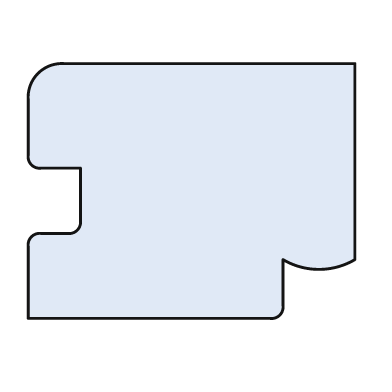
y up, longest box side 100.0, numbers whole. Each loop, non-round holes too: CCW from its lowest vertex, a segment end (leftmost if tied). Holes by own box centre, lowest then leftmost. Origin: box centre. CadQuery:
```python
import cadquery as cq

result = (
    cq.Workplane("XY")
    .moveTo(-50.0, -39.0)
    .lineTo(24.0, -39.0)
    .threePointArc((27.0, -38.0), (28.0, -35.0))
    .lineTo(28.0, -21.0)
    .threePointArc((39.0, -24.0), (50.0, -21.0))
    .lineTo(50.0, 39.0)
    .lineTo(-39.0, 39.0)
    .threePointArc((-47.0, 36.0), (-50.0, 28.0))
    .lineTo(-50.0, 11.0)
    .threePointArc((-49.0, 8.0), (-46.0, 7.0))
    .lineTo(-34.0, 7.0)
    .lineTo(-34.0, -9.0)
    .threePointArc((-35.0, -12.0), (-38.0, -13.0))
    .lineTo(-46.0, -13.0)
    .threePointArc((-49.0, -14.0), (-50.0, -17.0))
    .close()
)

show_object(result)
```